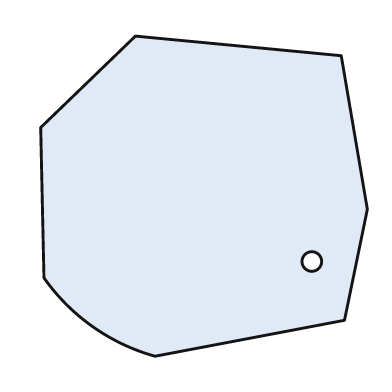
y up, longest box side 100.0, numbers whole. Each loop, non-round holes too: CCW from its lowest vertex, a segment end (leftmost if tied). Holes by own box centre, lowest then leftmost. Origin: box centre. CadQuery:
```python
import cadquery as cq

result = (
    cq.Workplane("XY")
    .moveTo(-15.0, -49.0)
    .lineTo(43.0, -38.0)
    .lineTo(50.0, -4.0)
    .lineTo(42.0, 43.0)
    .lineTo(-21.0, 49.0)
    .lineTo(-50.0, 21.0)
    .lineTo(-49.0, -25.0)
    .threePointArc((-34.0, -40.0), (-15.0, -49.0))
    .close()
    .moveTo(33.0, -20.0)
    .circle(3.0)
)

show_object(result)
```